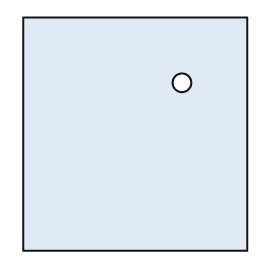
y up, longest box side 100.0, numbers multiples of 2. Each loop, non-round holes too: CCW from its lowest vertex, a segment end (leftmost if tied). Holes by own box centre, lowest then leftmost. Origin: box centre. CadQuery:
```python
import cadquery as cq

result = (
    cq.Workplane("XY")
    .moveTo(-48.0, -50.0)
    .lineTo(48.0, -50.0)
    .lineTo(48.0, 50.0)
    .lineTo(-48.0, 50.0)
    .close()
    .moveTo(20.0, 22.0)
    .circle(4.0)
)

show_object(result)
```